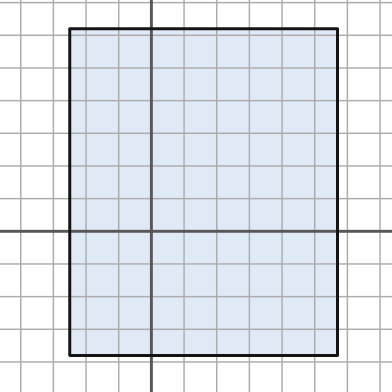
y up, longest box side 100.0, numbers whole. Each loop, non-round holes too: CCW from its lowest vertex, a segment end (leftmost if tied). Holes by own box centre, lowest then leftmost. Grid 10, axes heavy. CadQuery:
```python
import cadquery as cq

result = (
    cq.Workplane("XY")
    .moveTo(-25.0, -38.0)
    .lineTo(57.0, -38.0)
    .lineTo(57.0, 62.0)
    .lineTo(-25.0, 62.0)
    .close()
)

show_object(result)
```